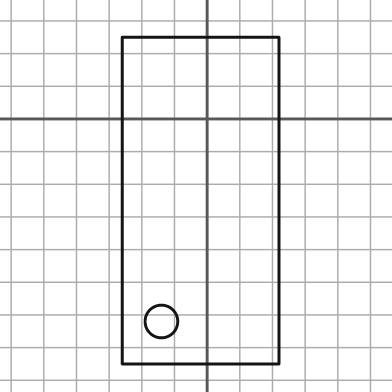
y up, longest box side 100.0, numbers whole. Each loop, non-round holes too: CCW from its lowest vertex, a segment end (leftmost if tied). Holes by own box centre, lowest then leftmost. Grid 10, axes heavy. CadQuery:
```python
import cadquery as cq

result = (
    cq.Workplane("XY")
    .moveTo(-26.0, -75.0)
    .lineTo(22.0, -75.0)
    .lineTo(22.0, 25.0)
    .lineTo(-26.0, 25.0)
    .close()
    .moveTo(-14.0, -62.0)
    .circle(5.0)
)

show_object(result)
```